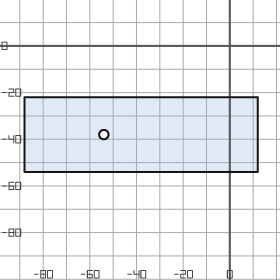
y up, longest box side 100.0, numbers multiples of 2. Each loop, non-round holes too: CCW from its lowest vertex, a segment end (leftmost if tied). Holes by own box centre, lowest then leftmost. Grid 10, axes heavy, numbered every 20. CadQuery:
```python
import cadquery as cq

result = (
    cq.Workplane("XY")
    .moveTo(-88.0, -54.0)
    .lineTo(12.0, -54.0)
    .lineTo(12.0, -22.0)
    .lineTo(-88.0, -22.0)
    .close()
    .moveTo(-54.0, -38.0)
    .circle(2.0)
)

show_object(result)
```